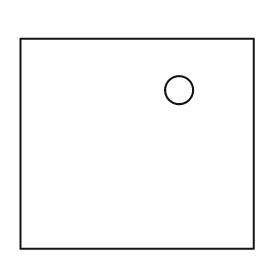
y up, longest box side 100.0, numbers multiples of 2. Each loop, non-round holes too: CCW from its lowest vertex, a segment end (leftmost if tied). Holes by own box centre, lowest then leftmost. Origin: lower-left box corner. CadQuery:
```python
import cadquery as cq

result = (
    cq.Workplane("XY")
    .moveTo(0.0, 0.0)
    .lineTo(100.0, 0.0)
    .lineTo(100.0, 90.0)
    .lineTo(0.0, 90.0)
    .close()
    .moveTo(68.0, 68.0)
    .circle(6.0)
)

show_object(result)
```